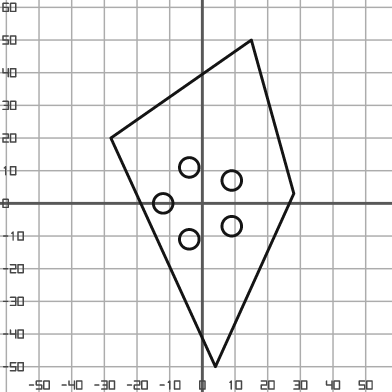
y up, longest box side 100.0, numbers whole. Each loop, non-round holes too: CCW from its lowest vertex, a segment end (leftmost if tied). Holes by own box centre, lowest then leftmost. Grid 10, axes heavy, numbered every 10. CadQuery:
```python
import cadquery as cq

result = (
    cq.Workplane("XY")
    .moveTo(4.0, -50.0)
    .lineTo(28.0, 3.0)
    .lineTo(15.0, 50.0)
    .lineTo(-28.0, 20.0)
    .close()
    .moveTo(-4.0, -11.0)
    .circle(3.0)
    .moveTo(9.0, -7.0)
    .circle(3.0)
    .moveTo(-12.0, 0.0)
    .circle(3.0)
    .moveTo(9.0, 7.0)
    .circle(3.0)
    .moveTo(-4.0, 11.0)
    .circle(3.0)
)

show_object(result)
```